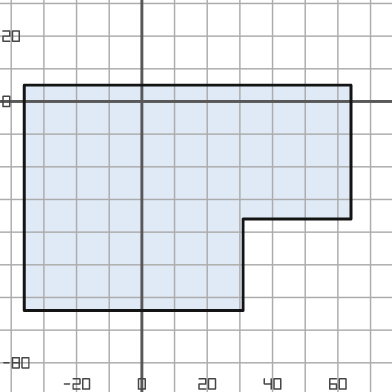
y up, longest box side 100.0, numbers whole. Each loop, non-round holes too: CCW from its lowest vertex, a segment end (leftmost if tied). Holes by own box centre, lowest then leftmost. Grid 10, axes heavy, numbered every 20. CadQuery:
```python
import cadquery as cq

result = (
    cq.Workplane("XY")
    .moveTo(-36.0, -64.0)
    .lineTo(31.0, -64.0)
    .lineTo(31.0, -36.0)
    .lineTo(64.0, -36.0)
    .lineTo(64.0, 5.0)
    .lineTo(-36.0, 5.0)
    .close()
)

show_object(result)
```